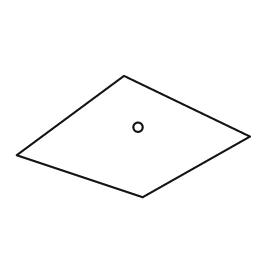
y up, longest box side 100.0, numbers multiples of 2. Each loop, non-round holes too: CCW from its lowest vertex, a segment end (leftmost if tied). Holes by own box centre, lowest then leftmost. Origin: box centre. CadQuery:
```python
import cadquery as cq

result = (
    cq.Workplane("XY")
    .moveTo(4.0, -26.0)
    .lineTo(50.0, 0.0)
    .lineTo(-4.0, 26.0)
    .lineTo(-50.0, -8.0)
    .close()
    .moveTo(2.0, 4.0)
    .circle(2.0)
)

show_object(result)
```